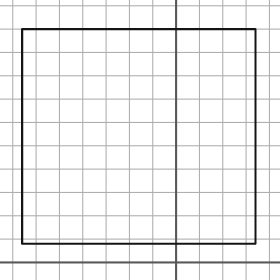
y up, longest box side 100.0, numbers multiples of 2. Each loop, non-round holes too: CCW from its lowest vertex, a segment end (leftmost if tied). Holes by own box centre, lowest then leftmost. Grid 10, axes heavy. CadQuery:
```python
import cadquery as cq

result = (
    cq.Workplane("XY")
    .moveTo(-66.0, 8.0)
    .lineTo(34.0, 8.0)
    .lineTo(34.0, 100.0)
    .lineTo(-66.0, 100.0)
    .close()
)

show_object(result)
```